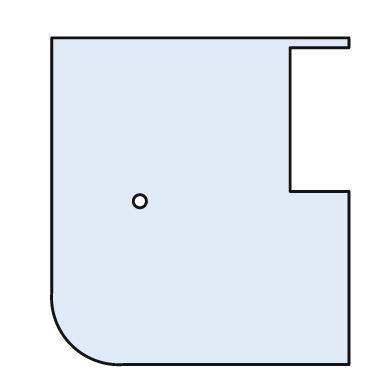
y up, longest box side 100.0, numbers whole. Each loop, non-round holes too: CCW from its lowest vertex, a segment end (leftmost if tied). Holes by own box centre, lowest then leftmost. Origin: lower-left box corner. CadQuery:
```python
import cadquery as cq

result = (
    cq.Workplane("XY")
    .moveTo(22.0, 0.0)
    .lineTo(91.0, 0.0)
    .lineTo(91.0, 53.0)
    .lineTo(73.0, 53.0)
    .lineTo(73.0, 97.0)
    .lineTo(91.0, 97.0)
    .lineTo(91.0, 100.0)
    .lineTo(0.0, 100.0)
    .lineTo(0.0, 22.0)
    .threePointArc((6.0, 6.0), (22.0, 0.0))
    .close()
    .moveTo(27.0, 50.0)
    .circle(2.0)
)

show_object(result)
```